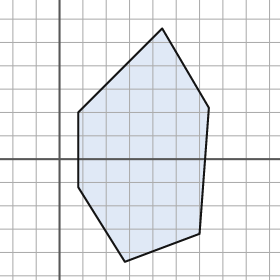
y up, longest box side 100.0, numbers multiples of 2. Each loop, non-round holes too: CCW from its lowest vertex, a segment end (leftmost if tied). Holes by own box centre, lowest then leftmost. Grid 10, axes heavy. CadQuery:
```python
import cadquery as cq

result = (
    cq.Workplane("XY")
    .moveTo(28.0, -44.0)
    .lineTo(60.0, -32.0)
    .lineTo(64.0, 22.0)
    .lineTo(44.0, 56.0)
    .lineTo(8.0, 20.0)
    .lineTo(8.0, -12.0)
    .close()
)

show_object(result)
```